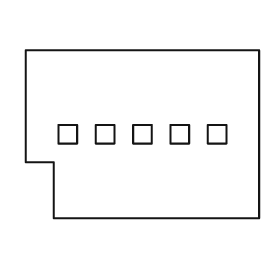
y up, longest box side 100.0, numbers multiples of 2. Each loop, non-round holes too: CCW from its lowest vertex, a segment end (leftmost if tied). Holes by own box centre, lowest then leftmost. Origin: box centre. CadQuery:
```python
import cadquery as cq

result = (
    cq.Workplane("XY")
    .moveTo(-38.0, -36.0)
    .lineTo(50.0, -36.0)
    .lineTo(50.0, 36.0)
    .lineTo(-50.0, 36.0)
    .lineTo(-50.0, -12.0)
    .lineTo(-38.0, -12.0)
    .close()
    .moveTo(-36.0, -4.0)
    .lineTo(-28.0, -4.0)
    .lineTo(-28.0, 4.0)
    .lineTo(-36.0, 4.0)
    .close()
    .moveTo(-20.0, -4.0)
    .lineTo(-12.0, -4.0)
    .lineTo(-12.0, 4.0)
    .lineTo(-20.0, 4.0)
    .close()
    .moveTo(-4.0, -4.0)
    .lineTo(4.0, -4.0)
    .lineTo(4.0, 4.0)
    .lineTo(-4.0, 4.0)
    .close()
    .moveTo(12.0, -4.0)
    .lineTo(20.0, -4.0)
    .lineTo(20.0, 4.0)
    .lineTo(12.0, 4.0)
    .close()
    .moveTo(28.0, -4.0)
    .lineTo(36.0, -4.0)
    .lineTo(36.0, 4.0)
    .lineTo(28.0, 4.0)
    .close()
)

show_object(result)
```